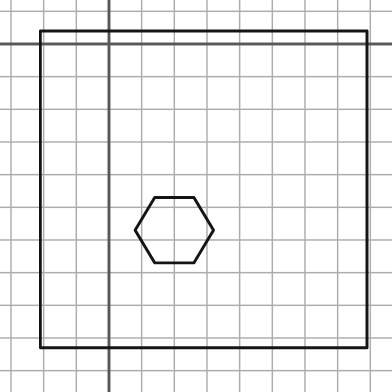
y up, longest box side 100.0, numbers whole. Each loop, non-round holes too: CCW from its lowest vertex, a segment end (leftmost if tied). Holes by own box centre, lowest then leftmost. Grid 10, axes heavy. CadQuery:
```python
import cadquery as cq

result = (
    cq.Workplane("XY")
    .moveTo(-21.0, -93.0)
    .lineTo(79.0, -93.0)
    .lineTo(79.0, 4.0)
    .lineTo(-21.0, 4.0)
    .close()
    .moveTo(14.0, -67.0)
    .lineTo(26.0, -67.0)
    .lineTo(32.0, -57.0)
    .lineTo(26.0, -47.0)
    .lineTo(14.0, -47.0)
    .lineTo(8.0, -57.0)
    .close()
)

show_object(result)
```